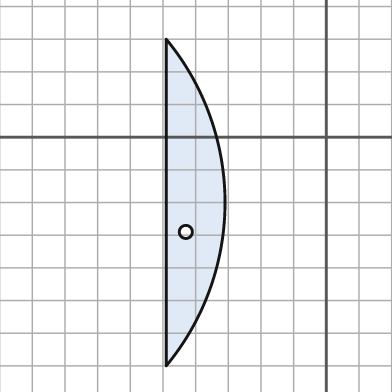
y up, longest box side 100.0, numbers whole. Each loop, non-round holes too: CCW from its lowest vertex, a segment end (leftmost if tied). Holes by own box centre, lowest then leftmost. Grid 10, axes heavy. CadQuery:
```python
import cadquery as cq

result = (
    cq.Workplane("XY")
    .moveTo(-49.0, -70.0)
    .threePointArc((-31.0, -20.0), (-49.0, 30.0))
    .close()
    .moveTo(-43.0, -29.0)
    .circle(2.0)
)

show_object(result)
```